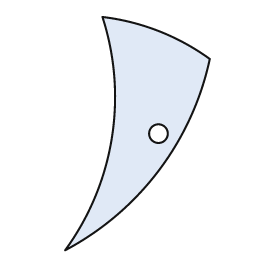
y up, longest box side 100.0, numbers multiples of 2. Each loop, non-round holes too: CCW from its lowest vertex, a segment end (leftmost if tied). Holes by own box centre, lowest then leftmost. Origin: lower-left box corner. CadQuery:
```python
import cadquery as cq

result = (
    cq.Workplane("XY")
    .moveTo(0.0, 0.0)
    .threePointArc((40.0, 34.0), (62.0, 82.0))
    .threePointArc((40.0, 94.0), (16.0, 100.0))
    .threePointArc((20.0, 48.0), (0.0, 0.0))
    .close()
    .moveTo(40.0, 50.0)
    .circle(4.0)
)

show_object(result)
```